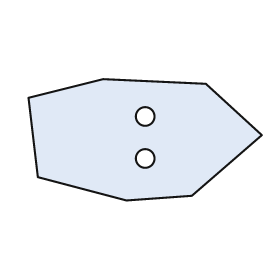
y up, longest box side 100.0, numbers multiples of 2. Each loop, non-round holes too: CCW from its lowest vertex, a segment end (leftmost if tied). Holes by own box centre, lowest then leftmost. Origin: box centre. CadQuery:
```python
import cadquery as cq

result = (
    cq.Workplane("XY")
    .moveTo(-8.0, -26.0)
    .lineTo(20.0, -24.0)
    .lineTo(50.0, 2.0)
    .lineTo(26.0, 24.0)
    .lineTo(-18.0, 26.0)
    .lineTo(-50.0, 18.0)
    .lineTo(-46.0, -16.0)
    .close()
    .moveTo(0.0, -8.0)
    .circle(4.0)
    .moveTo(0.0, 10.0)
    .circle(4.0)
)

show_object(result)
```